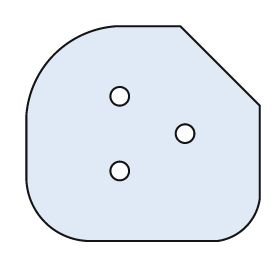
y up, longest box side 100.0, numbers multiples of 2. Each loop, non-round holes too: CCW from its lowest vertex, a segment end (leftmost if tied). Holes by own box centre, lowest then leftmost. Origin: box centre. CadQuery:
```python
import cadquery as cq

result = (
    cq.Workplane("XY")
    .moveTo(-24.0, -46.0)
    .lineTo(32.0, -46.0)
    .threePointArc((44.0, -40.0), (50.0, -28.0))
    .lineTo(50.0, 12.0)
    .lineTo(16.0, 46.0)
    .lineTo(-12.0, 46.0)
    .threePointArc((-38.0, 34.0), (-50.0, 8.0))
    .lineTo(-50.0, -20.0)
    .threePointArc((-42.0, -38.0), (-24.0, -46.0))
    .close()
    .moveTo(-10.0, -16.0)
    .circle(4.0)
    .moveTo(18.0, 0.0)
    .circle(4.0)
    .moveTo(-10.0, 16.0)
    .circle(4.0)
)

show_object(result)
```